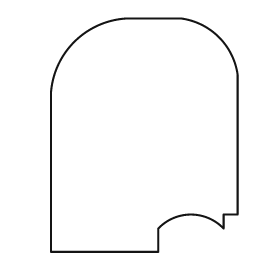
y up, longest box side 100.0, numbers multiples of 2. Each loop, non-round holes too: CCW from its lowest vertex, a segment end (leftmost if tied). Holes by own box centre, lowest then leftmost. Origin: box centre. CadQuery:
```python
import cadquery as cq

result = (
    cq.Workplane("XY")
    .moveTo(-40.0, -50.0)
    .lineTo(6.0, -50.0)
    .lineTo(6.0, -40.0)
    .threePointArc((20.0, -34.0), (34.0, -40.0))
    .lineTo(34.0, -34.0)
    .lineTo(40.0, -34.0)
    .lineTo(40.0, 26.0)
    .threePointArc((32.0, 42.0), (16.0, 50.0))
    .lineTo(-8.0, 50.0)
    .threePointArc((-30.0, 40.0), (-40.0, 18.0))
    .close()
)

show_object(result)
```